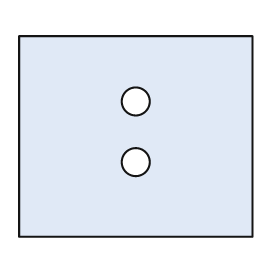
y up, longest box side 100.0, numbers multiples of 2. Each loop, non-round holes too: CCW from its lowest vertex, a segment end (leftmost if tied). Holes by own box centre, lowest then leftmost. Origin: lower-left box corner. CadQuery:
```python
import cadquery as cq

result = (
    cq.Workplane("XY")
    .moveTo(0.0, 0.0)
    .lineTo(100.0, 0.0)
    .lineTo(100.0, 86.0)
    .lineTo(0.0, 86.0)
    .close()
    .moveTo(50.0, 32.0)
    .circle(6.0)
    .moveTo(50.0, 58.0)
    .circle(6.0)
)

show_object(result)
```